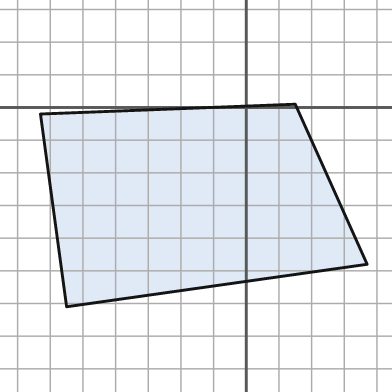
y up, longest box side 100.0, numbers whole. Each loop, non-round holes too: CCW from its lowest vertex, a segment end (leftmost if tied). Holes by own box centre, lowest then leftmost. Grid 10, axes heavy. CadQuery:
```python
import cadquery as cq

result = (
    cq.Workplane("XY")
    .moveTo(-55.0, -61.0)
    .lineTo(37.0, -48.0)
    .lineTo(15.0, 1.0)
    .lineTo(-63.0, -2.0)
    .close()
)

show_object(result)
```